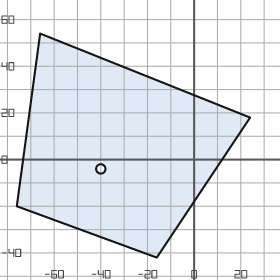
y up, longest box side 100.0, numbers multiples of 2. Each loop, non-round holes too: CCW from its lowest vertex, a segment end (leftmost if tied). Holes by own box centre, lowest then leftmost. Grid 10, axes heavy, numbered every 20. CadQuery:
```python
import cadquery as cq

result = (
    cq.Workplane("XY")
    .moveTo(-16.0, -42.0)
    .lineTo(24.0, 18.0)
    .lineTo(-66.0, 54.0)
    .lineTo(-76.0, -20.0)
    .close()
    .moveTo(-40.0, -4.0)
    .circle(2.0)
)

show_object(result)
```